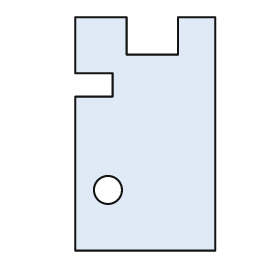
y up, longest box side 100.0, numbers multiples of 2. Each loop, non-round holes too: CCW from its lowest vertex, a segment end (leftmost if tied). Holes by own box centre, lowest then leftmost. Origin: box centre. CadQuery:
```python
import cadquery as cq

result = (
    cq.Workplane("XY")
    .moveTo(-30.0, -50.0)
    .lineTo(30.0, -50.0)
    .lineTo(30.0, 50.0)
    .lineTo(14.0, 50.0)
    .lineTo(14.0, 34.0)
    .lineTo(-8.0, 34.0)
    .lineTo(-8.0, 50.0)
    .lineTo(-30.0, 50.0)
    .lineTo(-30.0, 26.0)
    .lineTo(-14.0, 26.0)
    .lineTo(-14.0, 16.0)
    .lineTo(-30.0, 16.0)
    .close()
    .moveTo(-16.0, -24.0)
    .circle(6.0)
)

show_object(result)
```